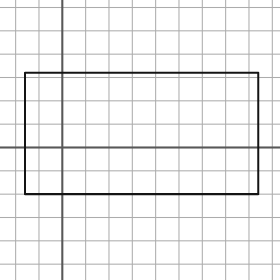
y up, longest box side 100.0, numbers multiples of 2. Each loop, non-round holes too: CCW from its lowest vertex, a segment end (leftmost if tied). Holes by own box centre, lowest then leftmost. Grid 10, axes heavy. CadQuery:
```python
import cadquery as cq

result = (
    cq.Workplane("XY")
    .moveTo(-16.0, -20.0)
    .lineTo(84.0, -20.0)
    .lineTo(84.0, 32.0)
    .lineTo(-16.0, 32.0)
    .close()
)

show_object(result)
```